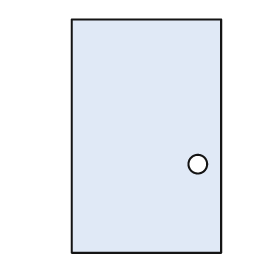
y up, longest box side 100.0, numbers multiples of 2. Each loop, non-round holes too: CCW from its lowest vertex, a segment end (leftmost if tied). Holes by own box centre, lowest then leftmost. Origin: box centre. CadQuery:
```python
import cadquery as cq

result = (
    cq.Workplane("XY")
    .moveTo(-32.0, -50.0)
    .lineTo(32.0, -50.0)
    .lineTo(32.0, 50.0)
    .lineTo(-32.0, 50.0)
    .close()
    .moveTo(22.0, -12.0)
    .circle(4.0)
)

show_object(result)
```